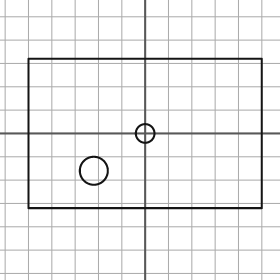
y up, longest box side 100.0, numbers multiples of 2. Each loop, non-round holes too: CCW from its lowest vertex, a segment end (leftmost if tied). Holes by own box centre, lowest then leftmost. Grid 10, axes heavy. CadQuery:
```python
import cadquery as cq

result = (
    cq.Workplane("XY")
    .moveTo(-50.0, -32.0)
    .lineTo(50.0, -32.0)
    .lineTo(50.0, 32.0)
    .lineTo(-50.0, 32.0)
    .close()
    .moveTo(-22.0, -16.0)
    .circle(6.0)
    .moveTo(0.0, 0.0)
    .circle(4.0)
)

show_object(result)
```